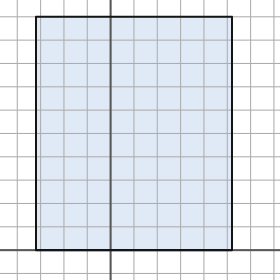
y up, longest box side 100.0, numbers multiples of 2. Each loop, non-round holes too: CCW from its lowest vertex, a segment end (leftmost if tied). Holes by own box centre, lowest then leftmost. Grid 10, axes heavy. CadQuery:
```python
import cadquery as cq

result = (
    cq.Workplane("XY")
    .moveTo(-32.0, 0.0)
    .lineTo(52.0, 0.0)
    .lineTo(52.0, 100.0)
    .lineTo(-32.0, 100.0)
    .close()
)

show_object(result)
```